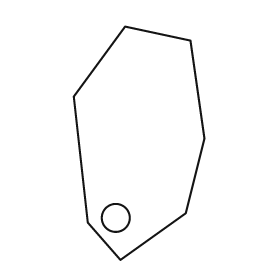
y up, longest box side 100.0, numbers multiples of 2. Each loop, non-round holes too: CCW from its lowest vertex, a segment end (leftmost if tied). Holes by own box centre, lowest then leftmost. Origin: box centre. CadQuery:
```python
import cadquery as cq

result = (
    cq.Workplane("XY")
    .moveTo(-8.0, -50.0)
    .lineTo(20.0, -30.0)
    .lineTo(28.0, 2.0)
    .lineTo(22.0, 44.0)
    .lineTo(-6.0, 50.0)
    .lineTo(-28.0, 20.0)
    .lineTo(-22.0, -34.0)
    .close()
    .moveTo(-10.0, -32.0)
    .circle(6.0)
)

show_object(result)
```